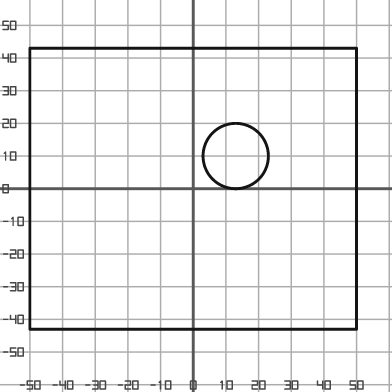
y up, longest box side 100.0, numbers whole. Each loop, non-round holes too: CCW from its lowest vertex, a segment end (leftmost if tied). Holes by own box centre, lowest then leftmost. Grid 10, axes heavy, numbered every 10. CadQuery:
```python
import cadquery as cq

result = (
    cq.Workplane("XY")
    .moveTo(-50.0, -43.0)
    .lineTo(50.0, -43.0)
    .lineTo(50.0, 43.0)
    .lineTo(-50.0, 43.0)
    .close()
    .moveTo(13.0, 10.0)
    .circle(10.0)
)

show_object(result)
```